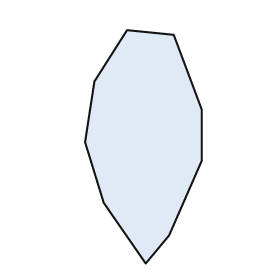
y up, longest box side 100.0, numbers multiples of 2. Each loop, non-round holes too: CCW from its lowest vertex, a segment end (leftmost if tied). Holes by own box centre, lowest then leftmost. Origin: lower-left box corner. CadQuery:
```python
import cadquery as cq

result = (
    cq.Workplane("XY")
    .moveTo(26.0, 0.0)
    .lineTo(36.0, 12.0)
    .lineTo(50.0, 44.0)
    .lineTo(50.0, 66.0)
    .lineTo(38.0, 98.0)
    .lineTo(18.0, 100.0)
    .lineTo(4.0, 78.0)
    .lineTo(0.0, 52.0)
    .lineTo(8.0, 26.0)
    .close()
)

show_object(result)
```